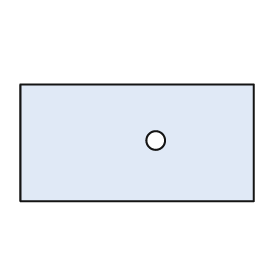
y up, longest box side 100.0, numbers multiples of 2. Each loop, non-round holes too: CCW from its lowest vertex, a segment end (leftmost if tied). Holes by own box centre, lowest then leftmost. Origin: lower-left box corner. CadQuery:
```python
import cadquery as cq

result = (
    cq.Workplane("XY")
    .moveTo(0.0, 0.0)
    .lineTo(100.0, 0.0)
    .lineTo(100.0, 50.0)
    .lineTo(0.0, 50.0)
    .close()
    .moveTo(58.0, 26.0)
    .circle(4.0)
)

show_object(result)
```